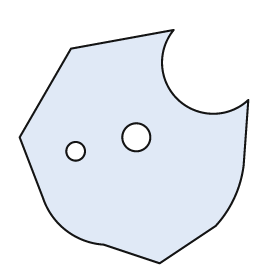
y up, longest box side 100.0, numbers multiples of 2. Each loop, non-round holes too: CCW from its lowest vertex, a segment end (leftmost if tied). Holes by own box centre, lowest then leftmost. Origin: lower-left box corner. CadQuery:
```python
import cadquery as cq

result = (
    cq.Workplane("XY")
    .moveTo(60.0, 0.0)
    .lineTo(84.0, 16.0)
    .threePointArc((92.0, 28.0), (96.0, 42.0))
    .lineTo(98.0, 70.0)
    .threePointArc((68.0, 70.0), (66.0, 100.0))
    .lineTo(22.0, 92.0)
    .lineTo(0.0, 54.0)
    .lineTo(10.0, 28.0)
    .threePointArc((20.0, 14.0), (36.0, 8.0))
    .close()
    .moveTo(24.0, 48.0)
    .circle(4.0)
    .moveTo(50.0, 54.0)
    .circle(6.0)
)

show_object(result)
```